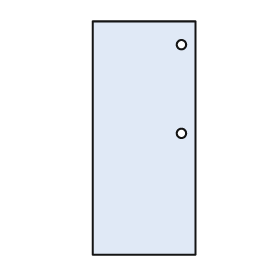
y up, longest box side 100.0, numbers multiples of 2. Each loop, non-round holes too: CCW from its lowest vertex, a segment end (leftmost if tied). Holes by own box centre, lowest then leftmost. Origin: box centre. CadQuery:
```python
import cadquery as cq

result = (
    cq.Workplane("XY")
    .moveTo(-22.0, -50.0)
    .lineTo(22.0, -50.0)
    .lineTo(22.0, 50.0)
    .lineTo(-22.0, 50.0)
    .close()
    .moveTo(16.0, 2.0)
    .circle(2.0)
    .moveTo(16.0, 40.0)
    .circle(2.0)
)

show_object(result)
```